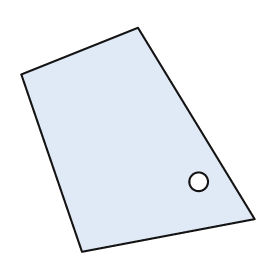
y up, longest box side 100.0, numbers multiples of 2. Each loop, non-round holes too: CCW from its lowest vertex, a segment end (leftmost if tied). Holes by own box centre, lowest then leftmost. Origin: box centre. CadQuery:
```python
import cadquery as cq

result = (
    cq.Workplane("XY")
    .moveTo(-24.0, -48.0)
    .lineTo(50.0, -34.0)
    .lineTo(0.0, 48.0)
    .lineTo(-50.0, 28.0)
    .close()
    .moveTo(26.0, -18.0)
    .circle(4.0)
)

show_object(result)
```